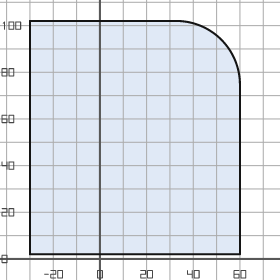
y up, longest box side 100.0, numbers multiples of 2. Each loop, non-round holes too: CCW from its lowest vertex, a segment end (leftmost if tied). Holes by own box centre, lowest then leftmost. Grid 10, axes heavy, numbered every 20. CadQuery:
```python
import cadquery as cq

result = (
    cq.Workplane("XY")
    .moveTo(-30.0, 2.0)
    .lineTo(60.0, 2.0)
    .lineTo(60.0, 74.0)
    .threePointArc((52.0, 94.0), (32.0, 102.0))
    .lineTo(-30.0, 102.0)
    .close()
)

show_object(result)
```